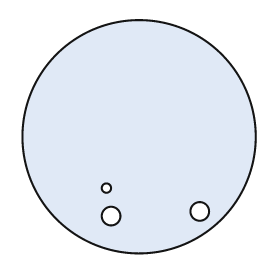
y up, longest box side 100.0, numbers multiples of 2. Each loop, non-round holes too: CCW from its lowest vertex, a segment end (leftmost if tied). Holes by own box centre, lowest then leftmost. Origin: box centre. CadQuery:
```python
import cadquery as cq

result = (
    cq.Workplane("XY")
    .moveTo(0.0, 0.0)
    .circle(50.0)
    .moveTo(-12.0, -34.0)
    .circle(4.0)
    .moveTo(26.0, -32.0)
    .circle(4.0)
    .moveTo(-14.0, -22.0)
    .circle(2.0)
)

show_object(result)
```